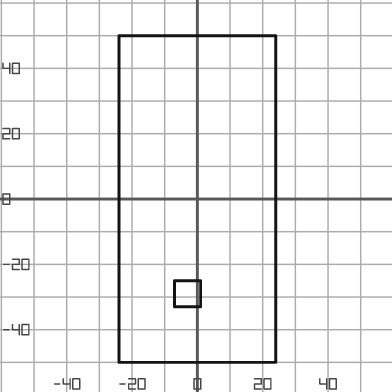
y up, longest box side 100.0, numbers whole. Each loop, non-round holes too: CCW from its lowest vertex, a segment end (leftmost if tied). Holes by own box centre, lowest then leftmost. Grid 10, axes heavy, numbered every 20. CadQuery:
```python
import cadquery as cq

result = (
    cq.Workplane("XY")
    .moveTo(-24.0, -50.0)
    .lineTo(24.0, -50.0)
    .lineTo(24.0, 50.0)
    .lineTo(-24.0, 50.0)
    .close()
    .moveTo(-7.0, -33.0)
    .lineTo(1.0, -33.0)
    .lineTo(1.0, -25.0)
    .lineTo(-7.0, -25.0)
    .close()
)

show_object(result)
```